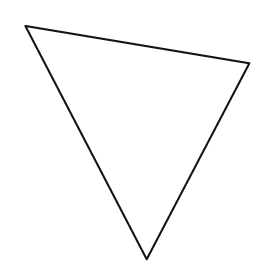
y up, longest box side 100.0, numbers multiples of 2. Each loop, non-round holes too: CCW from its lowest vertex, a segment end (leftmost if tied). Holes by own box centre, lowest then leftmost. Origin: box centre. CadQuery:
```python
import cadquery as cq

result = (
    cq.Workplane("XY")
    .moveTo(4.0, -50.0)
    .lineTo(48.0, 34.0)
    .lineTo(-48.0, 50.0)
    .close()
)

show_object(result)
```